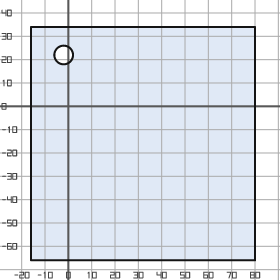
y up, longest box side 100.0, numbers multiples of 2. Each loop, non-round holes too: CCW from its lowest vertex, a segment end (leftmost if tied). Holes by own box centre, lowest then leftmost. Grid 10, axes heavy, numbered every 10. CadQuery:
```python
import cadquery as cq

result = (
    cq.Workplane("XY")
    .moveTo(-16.0, -66.0)
    .lineTo(80.0, -66.0)
    .lineTo(80.0, 34.0)
    .lineTo(-16.0, 34.0)
    .close()
    .moveTo(-2.0, 22.0)
    .circle(4.0)
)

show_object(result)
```